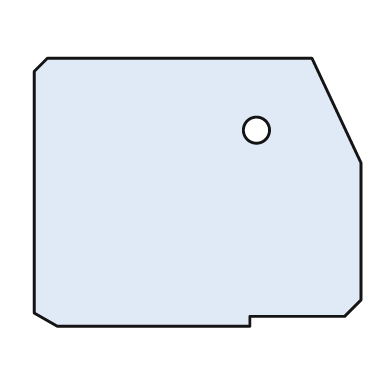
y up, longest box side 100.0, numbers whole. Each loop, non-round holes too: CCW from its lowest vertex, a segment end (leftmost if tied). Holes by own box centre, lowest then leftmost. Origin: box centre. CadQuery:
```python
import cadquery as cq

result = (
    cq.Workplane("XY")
    .moveTo(-43.0, -41.0)
    .lineTo(16.0, -41.0)
    .lineTo(16.0, -38.0)
    .lineTo(45.0, -38.0)
    .lineTo(50.0, -33.0)
    .lineTo(50.0, 9.0)
    .lineTo(35.0, 41.0)
    .lineTo(-46.0, 41.0)
    .lineTo(-50.0, 37.0)
    .lineTo(-50.0, -37.0)
    .close()
    .moveTo(18.0, 19.0)
    .circle(4.0)
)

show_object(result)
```